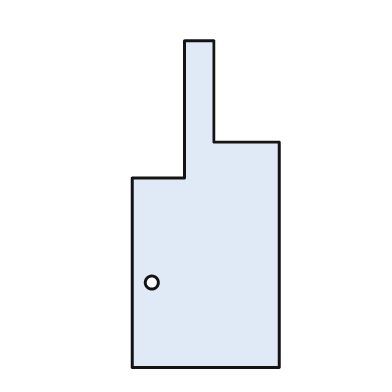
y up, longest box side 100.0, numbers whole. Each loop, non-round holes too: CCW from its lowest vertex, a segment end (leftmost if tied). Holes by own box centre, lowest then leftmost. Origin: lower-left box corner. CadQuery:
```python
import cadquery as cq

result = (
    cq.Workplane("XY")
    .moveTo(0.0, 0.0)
    .lineTo(45.0, 0.0)
    .lineTo(45.0, 69.0)
    .lineTo(25.0, 69.0)
    .lineTo(25.0, 100.0)
    .lineTo(16.0, 100.0)
    .lineTo(16.0, 58.0)
    .lineTo(0.0, 58.0)
    .close()
    .moveTo(6.0, 26.0)
    .circle(2.0)
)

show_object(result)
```